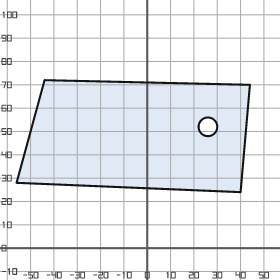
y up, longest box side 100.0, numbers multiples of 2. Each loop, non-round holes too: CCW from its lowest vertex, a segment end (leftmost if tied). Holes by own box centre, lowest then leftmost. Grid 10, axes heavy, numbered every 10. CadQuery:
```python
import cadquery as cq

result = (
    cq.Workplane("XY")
    .moveTo(40.0, 24.0)
    .lineTo(44.0, 70.0)
    .lineTo(-44.0, 72.0)
    .lineTo(-56.0, 28.0)
    .close()
    .moveTo(26.0, 52.0)
    .circle(4.0)
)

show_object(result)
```